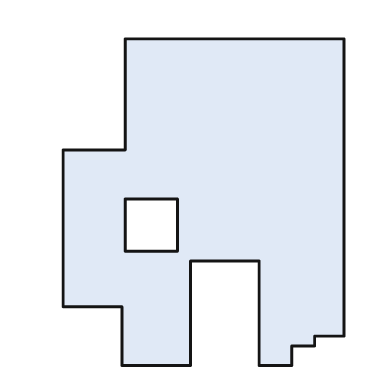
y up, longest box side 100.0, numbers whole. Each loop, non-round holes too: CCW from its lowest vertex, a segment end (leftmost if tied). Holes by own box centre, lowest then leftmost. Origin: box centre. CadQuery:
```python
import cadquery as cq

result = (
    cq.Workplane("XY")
    .moveTo(-25.0, -50.0)
    .lineTo(-4.0, -50.0)
    .lineTo(-4.0, -18.0)
    .lineTo(17.0, -18.0)
    .lineTo(17.0, -50.0)
    .lineTo(27.0, -50.0)
    .lineTo(27.0, -44.0)
    .lineTo(34.0, -44.0)
    .lineTo(34.0, -41.0)
    .lineTo(43.0, -41.0)
    .lineTo(43.0, 50.0)
    .lineTo(-24.0, 50.0)
    .lineTo(-24.0, 16.0)
    .lineTo(-43.0, 16.0)
    .lineTo(-43.0, -32.0)
    .lineTo(-25.0, -32.0)
    .close()
    .moveTo(-24.0, -15.0)
    .lineTo(-8.0, -15.0)
    .lineTo(-8.0, 1.0)
    .lineTo(-24.0, 1.0)
    .close()
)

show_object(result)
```